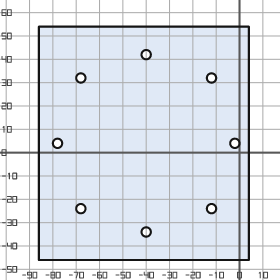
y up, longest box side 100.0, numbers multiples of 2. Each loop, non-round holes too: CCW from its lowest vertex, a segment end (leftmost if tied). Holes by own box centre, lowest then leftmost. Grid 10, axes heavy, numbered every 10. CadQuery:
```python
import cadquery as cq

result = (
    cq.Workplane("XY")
    .moveTo(-86.0, -46.0)
    .lineTo(4.0, -46.0)
    .lineTo(4.0, 54.0)
    .lineTo(-86.0, 54.0)
    .close()
    .moveTo(-40.0, -34.0)
    .circle(2.0)
    .moveTo(-68.0, -24.0)
    .circle(2.0)
    .moveTo(-12.0, -24.0)
    .circle(2.0)
    .moveTo(-78.0, 4.0)
    .circle(2.0)
    .moveTo(-2.0, 4.0)
    .circle(2.0)
    .moveTo(-68.0, 32.0)
    .circle(2.0)
    .moveTo(-12.0, 32.0)
    .circle(2.0)
    .moveTo(-40.0, 42.0)
    .circle(2.0)
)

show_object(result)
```